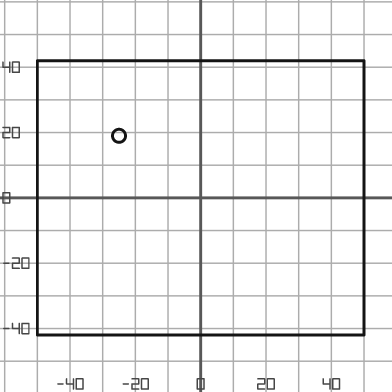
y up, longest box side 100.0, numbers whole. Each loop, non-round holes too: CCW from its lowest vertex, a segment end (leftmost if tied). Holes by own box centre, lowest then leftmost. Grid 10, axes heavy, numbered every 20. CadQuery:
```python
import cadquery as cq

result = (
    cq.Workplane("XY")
    .moveTo(-50.0, -42.0)
    .lineTo(50.0, -42.0)
    .lineTo(50.0, 42.0)
    .lineTo(-50.0, 42.0)
    .close()
    .moveTo(-25.0, 19.0)
    .circle(2.0)
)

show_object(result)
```